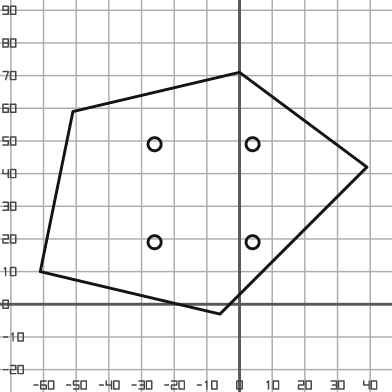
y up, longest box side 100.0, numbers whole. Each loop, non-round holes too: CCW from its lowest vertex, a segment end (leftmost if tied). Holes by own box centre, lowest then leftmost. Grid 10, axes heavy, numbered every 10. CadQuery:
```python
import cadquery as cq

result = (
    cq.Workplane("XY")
    .moveTo(-6.0, -3.0)
    .lineTo(39.0, 42.0)
    .lineTo(0.0, 71.0)
    .lineTo(-51.0, 59.0)
    .lineTo(-61.0, 10.0)
    .close()
    .moveTo(-26.0, 19.0)
    .circle(2.0)
    .moveTo(4.0, 19.0)
    .circle(2.0)
    .moveTo(-26.0, 49.0)
    .circle(2.0)
    .moveTo(4.0, 49.0)
    .circle(2.0)
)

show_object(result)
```